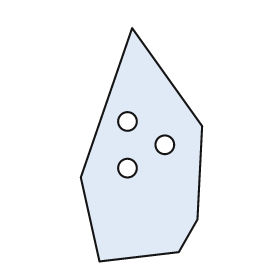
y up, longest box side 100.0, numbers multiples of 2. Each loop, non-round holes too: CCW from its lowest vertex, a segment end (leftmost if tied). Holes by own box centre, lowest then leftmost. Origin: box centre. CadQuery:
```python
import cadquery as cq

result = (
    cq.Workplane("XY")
    .moveTo(-18.0, -50.0)
    .lineTo(16.0, -46.0)
    .lineTo(24.0, -32.0)
    .lineTo(26.0, 8.0)
    .lineTo(-4.0, 50.0)
    .lineTo(-26.0, -14.0)
    .close()
    .moveTo(-6.0, -10.0)
    .circle(4.0)
    .moveTo(10.0, 0.0)
    .circle(4.0)
    .moveTo(-6.0, 10.0)
    .circle(4.0)
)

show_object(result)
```